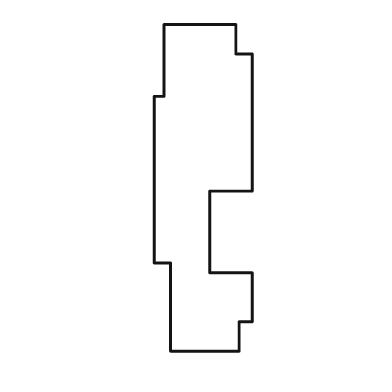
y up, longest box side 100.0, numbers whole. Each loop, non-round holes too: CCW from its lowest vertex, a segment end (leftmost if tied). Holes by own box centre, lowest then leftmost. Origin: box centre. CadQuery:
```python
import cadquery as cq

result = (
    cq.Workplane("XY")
    .moveTo(-10.0, -50.0)
    .lineTo(11.0, -50.0)
    .lineTo(11.0, -41.0)
    .lineTo(15.0, -41.0)
    .lineTo(15.0, -26.0)
    .lineTo(2.0, -26.0)
    .lineTo(2.0, -1.0)
    .lineTo(15.0, -1.0)
    .lineTo(15.0, 41.0)
    .lineTo(10.0, 41.0)
    .lineTo(10.0, 50.0)
    .lineTo(-12.0, 50.0)
    .lineTo(-12.0, 28.0)
    .lineTo(-15.0, 28.0)
    .lineTo(-15.0, -23.0)
    .lineTo(-10.0, -23.0)
    .close()
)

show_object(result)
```